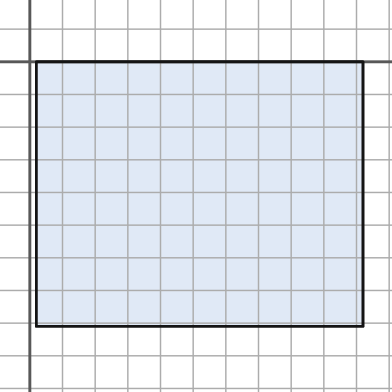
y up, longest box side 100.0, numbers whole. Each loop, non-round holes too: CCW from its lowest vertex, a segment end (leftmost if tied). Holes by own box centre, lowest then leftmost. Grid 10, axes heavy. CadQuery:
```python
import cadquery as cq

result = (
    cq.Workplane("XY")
    .moveTo(2.0, -81.0)
    .lineTo(102.0, -81.0)
    .lineTo(102.0, 0.0)
    .lineTo(2.0, 0.0)
    .close()
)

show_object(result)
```